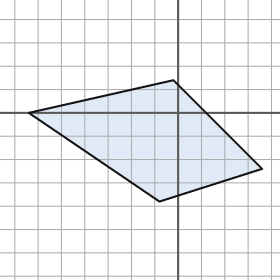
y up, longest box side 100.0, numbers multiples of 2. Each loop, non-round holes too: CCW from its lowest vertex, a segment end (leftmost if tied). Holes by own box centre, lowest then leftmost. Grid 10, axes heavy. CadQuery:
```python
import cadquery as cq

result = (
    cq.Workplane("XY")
    .moveTo(-8.0, -38.0)
    .lineTo(36.0, -24.0)
    .lineTo(-2.0, 14.0)
    .lineTo(-64.0, 0.0)
    .close()
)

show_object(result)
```